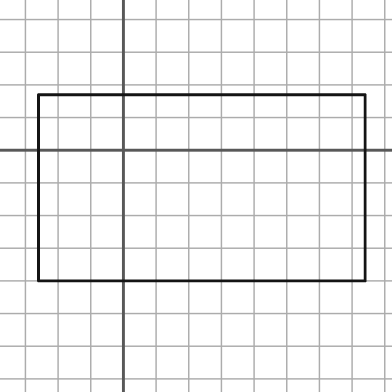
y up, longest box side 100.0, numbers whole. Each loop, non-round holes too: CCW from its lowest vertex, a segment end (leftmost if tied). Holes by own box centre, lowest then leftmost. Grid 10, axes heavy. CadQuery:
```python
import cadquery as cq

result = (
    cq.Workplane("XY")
    .moveTo(-26.0, -40.0)
    .lineTo(74.0, -40.0)
    .lineTo(74.0, 17.0)
    .lineTo(-26.0, 17.0)
    .close()
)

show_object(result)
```